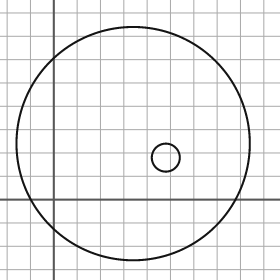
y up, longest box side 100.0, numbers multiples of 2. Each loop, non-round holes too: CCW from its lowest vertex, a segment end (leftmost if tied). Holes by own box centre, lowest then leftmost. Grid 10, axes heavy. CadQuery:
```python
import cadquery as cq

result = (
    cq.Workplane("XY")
    .moveTo(34.0, 24.0)
    .circle(50.0)
    .moveTo(48.0, 18.0)
    .circle(6.0)
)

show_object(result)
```